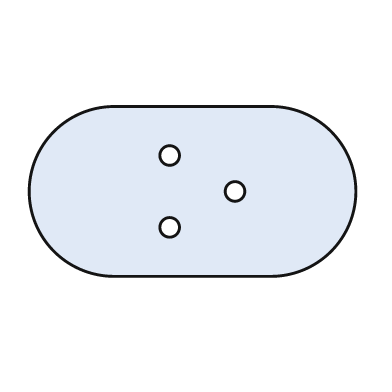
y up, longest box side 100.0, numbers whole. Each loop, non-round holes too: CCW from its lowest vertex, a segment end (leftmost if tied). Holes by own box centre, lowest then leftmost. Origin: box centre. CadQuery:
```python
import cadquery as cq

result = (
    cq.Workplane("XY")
    .moveTo(-24.0, -26.0)
    .lineTo(24.0, -26.0)
    .threePointArc((50.0, 0.0), (24.0, 26.0))
    .lineTo(-24.0, 26.0)
    .threePointArc((-50.0, 0.0), (-24.0, -26.0))
    .close()
    .moveTo(-7.0, -11.0)
    .circle(3.0)
    .moveTo(13.0, 0.0)
    .circle(3.0)
    .moveTo(-7.0, 11.0)
    .circle(3.0)
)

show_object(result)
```